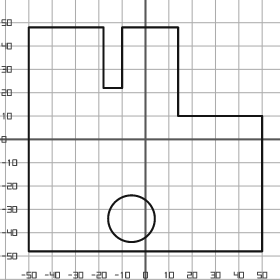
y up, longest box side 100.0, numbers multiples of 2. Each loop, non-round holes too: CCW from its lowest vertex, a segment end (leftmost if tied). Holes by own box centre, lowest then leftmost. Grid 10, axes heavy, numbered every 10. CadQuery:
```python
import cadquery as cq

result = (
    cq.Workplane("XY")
    .moveTo(-50.0, -48.0)
    .lineTo(50.0, -48.0)
    .lineTo(50.0, 10.0)
    .lineTo(14.0, 10.0)
    .lineTo(14.0, 48.0)
    .lineTo(-10.0, 48.0)
    .lineTo(-10.0, 22.0)
    .lineTo(-18.0, 22.0)
    .lineTo(-18.0, 48.0)
    .lineTo(-50.0, 48.0)
    .close()
    .moveTo(-6.0, -34.0)
    .circle(10.0)
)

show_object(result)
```